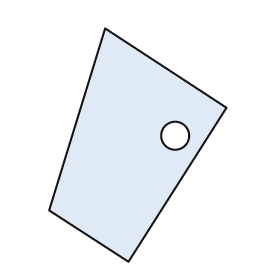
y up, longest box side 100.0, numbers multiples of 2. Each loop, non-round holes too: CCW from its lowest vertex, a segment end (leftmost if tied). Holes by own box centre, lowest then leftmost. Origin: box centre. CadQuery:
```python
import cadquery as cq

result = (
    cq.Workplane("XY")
    .moveTo(-4.0, -50.0)
    .lineTo(38.0, 16.0)
    .lineTo(-14.0, 50.0)
    .lineTo(-38.0, -28.0)
    .close()
    .moveTo(16.0, 4.0)
    .circle(6.0)
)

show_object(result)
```